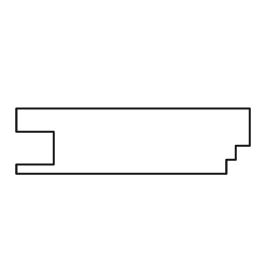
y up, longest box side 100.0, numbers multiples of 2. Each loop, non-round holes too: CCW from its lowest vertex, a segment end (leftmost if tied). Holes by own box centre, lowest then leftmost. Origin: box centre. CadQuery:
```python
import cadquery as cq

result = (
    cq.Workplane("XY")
    .moveTo(-50.0, -14.0)
    .lineTo(40.0, -14.0)
    .lineTo(40.0, -8.0)
    .lineTo(44.0, -8.0)
    .lineTo(44.0, -2.0)
    .lineTo(50.0, -2.0)
    .lineTo(50.0, 14.0)
    .lineTo(-50.0, 14.0)
    .lineTo(-50.0, 4.0)
    .lineTo(-34.0, 4.0)
    .lineTo(-34.0, -10.0)
    .lineTo(-50.0, -10.0)
    .close()
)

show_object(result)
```